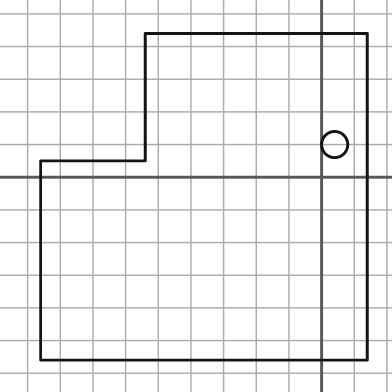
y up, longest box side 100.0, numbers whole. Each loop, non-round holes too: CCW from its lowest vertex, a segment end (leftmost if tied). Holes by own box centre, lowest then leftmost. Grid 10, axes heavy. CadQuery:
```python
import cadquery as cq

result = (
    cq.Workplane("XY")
    .moveTo(-86.0, -56.0)
    .lineTo(14.0, -56.0)
    .lineTo(14.0, 44.0)
    .lineTo(-54.0, 44.0)
    .lineTo(-54.0, 5.0)
    .lineTo(-86.0, 5.0)
    .close()
    .moveTo(4.0, 10.0)
    .circle(4.0)
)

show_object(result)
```